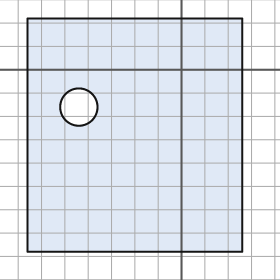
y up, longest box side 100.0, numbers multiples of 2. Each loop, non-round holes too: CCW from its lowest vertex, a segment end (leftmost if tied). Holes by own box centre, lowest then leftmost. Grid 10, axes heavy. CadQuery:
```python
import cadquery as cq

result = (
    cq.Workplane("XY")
    .moveTo(-66.0, -78.0)
    .lineTo(26.0, -78.0)
    .lineTo(26.0, 22.0)
    .lineTo(-66.0, 22.0)
    .close()
    .moveTo(-44.0, -16.0)
    .circle(8.0)
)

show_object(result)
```